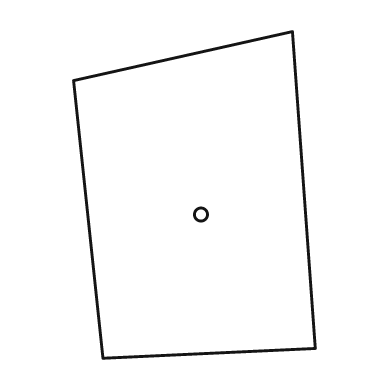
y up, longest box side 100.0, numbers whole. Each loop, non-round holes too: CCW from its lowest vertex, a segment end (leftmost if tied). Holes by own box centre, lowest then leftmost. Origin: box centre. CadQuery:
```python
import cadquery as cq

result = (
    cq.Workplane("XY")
    .moveTo(-28.0, -50.0)
    .lineTo(37.0, -47.0)
    .lineTo(30.0, 50.0)
    .lineTo(-37.0, 35.0)
    .close()
    .moveTo(2.0, -6.0)
    .circle(2.0)
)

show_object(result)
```